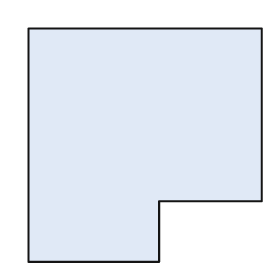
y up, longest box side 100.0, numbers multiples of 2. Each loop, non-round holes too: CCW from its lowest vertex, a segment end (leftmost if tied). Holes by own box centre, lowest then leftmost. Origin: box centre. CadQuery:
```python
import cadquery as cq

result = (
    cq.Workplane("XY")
    .moveTo(-50.0, -50.0)
    .lineTo(6.0, -50.0)
    .lineTo(6.0, -24.0)
    .lineTo(50.0, -24.0)
    .lineTo(50.0, 50.0)
    .lineTo(-50.0, 50.0)
    .close()
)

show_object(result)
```